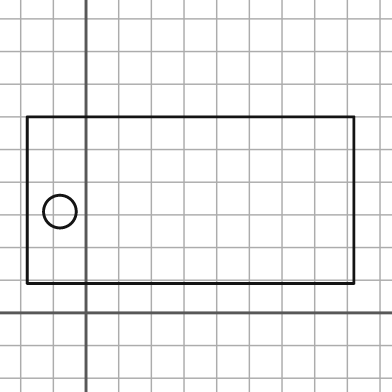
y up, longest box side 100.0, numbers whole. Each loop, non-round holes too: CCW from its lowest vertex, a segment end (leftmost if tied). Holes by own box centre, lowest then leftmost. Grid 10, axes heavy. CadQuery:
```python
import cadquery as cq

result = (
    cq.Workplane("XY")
    .moveTo(-18.0, 9.0)
    .lineTo(82.0, 9.0)
    .lineTo(82.0, 60.0)
    .lineTo(-18.0, 60.0)
    .close()
    .moveTo(-8.0, 31.0)
    .circle(5.0)
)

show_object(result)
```